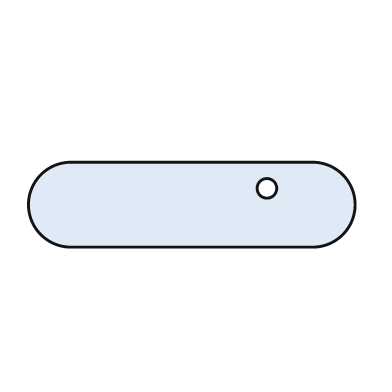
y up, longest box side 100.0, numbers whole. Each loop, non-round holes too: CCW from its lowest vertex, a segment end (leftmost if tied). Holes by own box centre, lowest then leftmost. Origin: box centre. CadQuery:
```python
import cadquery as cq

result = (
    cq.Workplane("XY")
    .moveTo(-37.0, -13.0)
    .lineTo(37.0, -13.0)
    .threePointArc((50.0, 0.0), (37.0, 13.0))
    .lineTo(-37.0, 13.0)
    .threePointArc((-50.0, 0.0), (-37.0, -13.0))
    .close()
    .moveTo(23.0, 5.0)
    .circle(3.0)
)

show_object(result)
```